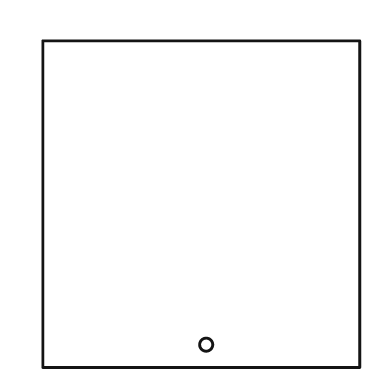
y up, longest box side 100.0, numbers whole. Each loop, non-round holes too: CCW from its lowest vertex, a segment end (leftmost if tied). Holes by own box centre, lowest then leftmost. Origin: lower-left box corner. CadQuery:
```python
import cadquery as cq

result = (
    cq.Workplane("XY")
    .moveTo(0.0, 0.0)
    .lineTo(97.0, 0.0)
    .lineTo(97.0, 100.0)
    .lineTo(0.0, 100.0)
    .close()
    .moveTo(50.0, 7.0)
    .circle(2.0)
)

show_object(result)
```